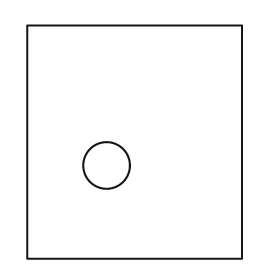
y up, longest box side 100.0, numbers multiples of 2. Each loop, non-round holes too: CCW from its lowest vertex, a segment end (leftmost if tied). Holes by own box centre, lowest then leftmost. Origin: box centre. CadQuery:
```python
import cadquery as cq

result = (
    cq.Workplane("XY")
    .moveTo(-46.0, -50.0)
    .lineTo(46.0, -50.0)
    .lineTo(46.0, 50.0)
    .lineTo(-46.0, 50.0)
    .close()
    .moveTo(-12.0, -10.0)
    .circle(10.0)
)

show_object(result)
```